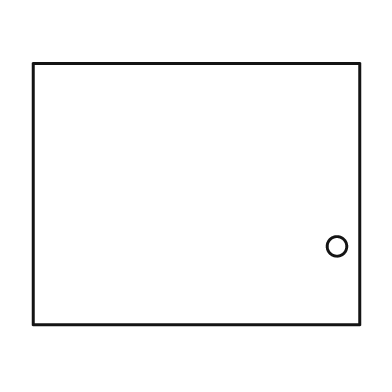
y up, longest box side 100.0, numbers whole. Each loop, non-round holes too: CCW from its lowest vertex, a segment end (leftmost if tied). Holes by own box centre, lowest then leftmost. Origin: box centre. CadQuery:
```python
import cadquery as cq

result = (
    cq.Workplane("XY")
    .moveTo(-50.0, -40.0)
    .lineTo(50.0, -40.0)
    .lineTo(50.0, 40.0)
    .lineTo(-50.0, 40.0)
    .close()
    .moveTo(43.0, -16.0)
    .circle(3.0)
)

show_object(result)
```